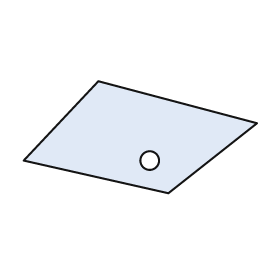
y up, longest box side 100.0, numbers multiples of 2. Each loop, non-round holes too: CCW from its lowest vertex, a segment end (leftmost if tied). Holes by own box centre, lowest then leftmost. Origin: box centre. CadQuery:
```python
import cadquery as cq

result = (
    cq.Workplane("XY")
    .moveTo(12.0, -24.0)
    .lineTo(50.0, 6.0)
    .lineTo(-18.0, 24.0)
    .lineTo(-50.0, -10.0)
    .close()
    .moveTo(4.0, -10.0)
    .circle(4.0)
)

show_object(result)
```